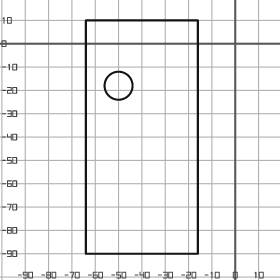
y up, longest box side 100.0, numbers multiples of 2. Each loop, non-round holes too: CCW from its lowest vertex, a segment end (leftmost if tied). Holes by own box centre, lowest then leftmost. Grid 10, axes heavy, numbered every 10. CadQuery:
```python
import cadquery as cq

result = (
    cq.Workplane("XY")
    .moveTo(-64.0, -90.0)
    .lineTo(-16.0, -90.0)
    .lineTo(-16.0, 10.0)
    .lineTo(-64.0, 10.0)
    .close()
    .moveTo(-50.0, -18.0)
    .circle(6.0)
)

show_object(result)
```